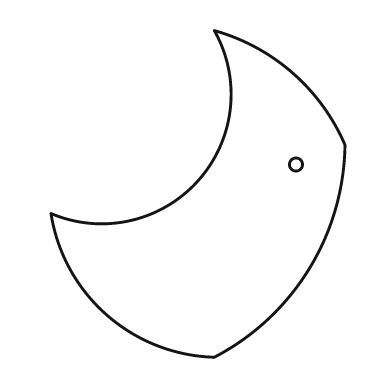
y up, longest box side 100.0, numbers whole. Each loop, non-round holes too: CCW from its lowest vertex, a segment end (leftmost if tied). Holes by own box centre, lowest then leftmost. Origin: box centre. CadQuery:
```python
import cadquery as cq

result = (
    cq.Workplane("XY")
    .moveTo(5.0, -50.0)
    .threePointArc((34.0, -23.0), (45.0, 15.0))
    .threePointArc((29.0, 37.0), (5.0, 50.0))
    .threePointArc((0.0, 4.0), (-45.0, -6.0))
    .threePointArc((-28.0, -37.0), (5.0, -50.0))
    .close()
    .moveTo(30.0, 9.0)
    .circle(2.0)
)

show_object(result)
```